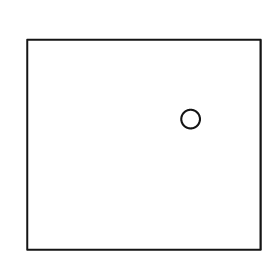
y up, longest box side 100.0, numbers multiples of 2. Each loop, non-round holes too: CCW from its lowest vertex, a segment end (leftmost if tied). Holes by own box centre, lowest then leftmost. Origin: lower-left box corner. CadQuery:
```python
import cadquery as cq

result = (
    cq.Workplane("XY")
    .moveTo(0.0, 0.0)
    .lineTo(100.0, 0.0)
    .lineTo(100.0, 90.0)
    .lineTo(0.0, 90.0)
    .close()
    .moveTo(70.0, 56.0)
    .circle(4.0)
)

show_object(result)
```